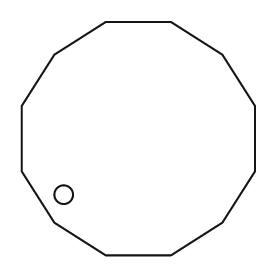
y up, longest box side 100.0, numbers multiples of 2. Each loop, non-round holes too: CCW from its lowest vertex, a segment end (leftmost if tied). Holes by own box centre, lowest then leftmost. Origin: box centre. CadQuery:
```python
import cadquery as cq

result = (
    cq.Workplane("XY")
    .moveTo(-14.0, -50.0)
    .lineTo(14.0, -50.0)
    .lineTo(36.0, -36.0)
    .lineTo(50.0, -14.0)
    .lineTo(50.0, 14.0)
    .lineTo(36.0, 36.0)
    .lineTo(14.0, 50.0)
    .lineTo(-14.0, 50.0)
    .lineTo(-36.0, 36.0)
    .lineTo(-50.0, 14.0)
    .lineTo(-50.0, -14.0)
    .lineTo(-36.0, -36.0)
    .close()
    .moveTo(-32.0, -24.0)
    .circle(4.0)
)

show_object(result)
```